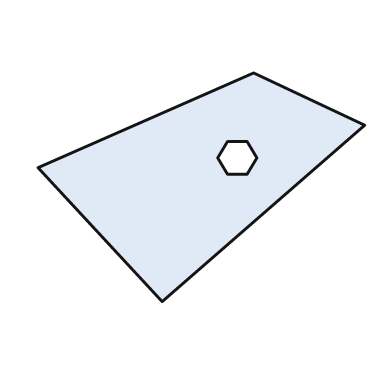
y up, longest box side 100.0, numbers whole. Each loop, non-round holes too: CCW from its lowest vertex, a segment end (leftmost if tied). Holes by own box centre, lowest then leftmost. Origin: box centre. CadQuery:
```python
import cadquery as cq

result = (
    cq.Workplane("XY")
    .moveTo(-12.0, -35.0)
    .lineTo(50.0, 19.0)
    .lineTo(16.0, 35.0)
    .lineTo(-50.0, 6.0)
    .close()
    .moveTo(8.0, 4.0)
    .lineTo(14.0, 4.0)
    .lineTo(17.0, 9.0)
    .lineTo(14.0, 14.0)
    .lineTo(8.0, 14.0)
    .lineTo(5.0, 9.0)
    .close()
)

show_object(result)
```